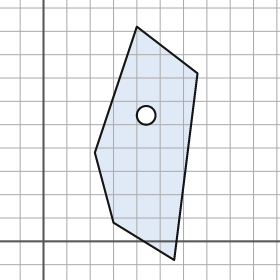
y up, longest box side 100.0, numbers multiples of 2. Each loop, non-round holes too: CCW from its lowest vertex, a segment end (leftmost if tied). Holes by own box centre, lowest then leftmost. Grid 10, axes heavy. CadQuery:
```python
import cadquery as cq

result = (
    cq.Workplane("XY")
    .moveTo(56.0, -8.0)
    .lineTo(66.0, 72.0)
    .lineTo(40.0, 92.0)
    .lineTo(22.0, 38.0)
    .lineTo(30.0, 8.0)
    .close()
    .moveTo(44.0, 54.0)
    .circle(4.0)
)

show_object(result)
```